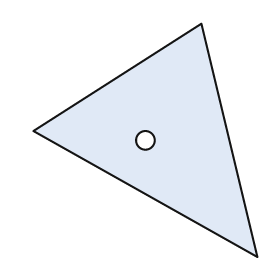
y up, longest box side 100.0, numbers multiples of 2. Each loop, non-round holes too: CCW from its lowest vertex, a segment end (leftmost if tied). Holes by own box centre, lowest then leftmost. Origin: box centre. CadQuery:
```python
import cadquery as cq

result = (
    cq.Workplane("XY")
    .moveTo(48.0, -50.0)
    .lineTo(24.0, 50.0)
    .lineTo(-48.0, 4.0)
    .close()
    .moveTo(0.0, 0.0)
    .circle(4.0)
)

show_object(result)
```